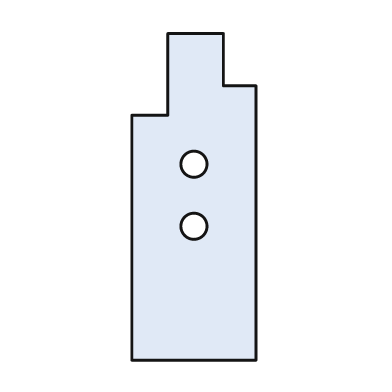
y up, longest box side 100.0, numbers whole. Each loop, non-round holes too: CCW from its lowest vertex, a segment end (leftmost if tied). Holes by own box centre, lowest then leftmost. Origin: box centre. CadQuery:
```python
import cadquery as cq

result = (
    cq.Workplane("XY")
    .moveTo(-19.0, -50.0)
    .lineTo(19.0, -50.0)
    .lineTo(19.0, 34.0)
    .lineTo(9.0, 34.0)
    .lineTo(9.0, 50.0)
    .lineTo(-8.0, 50.0)
    .lineTo(-8.0, 25.0)
    .lineTo(-19.0, 25.0)
    .close()
    .moveTo(0.0, -9.0)
    .circle(4.0)
    .moveTo(0.0, 10.0)
    .circle(4.0)
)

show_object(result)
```